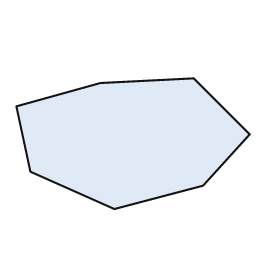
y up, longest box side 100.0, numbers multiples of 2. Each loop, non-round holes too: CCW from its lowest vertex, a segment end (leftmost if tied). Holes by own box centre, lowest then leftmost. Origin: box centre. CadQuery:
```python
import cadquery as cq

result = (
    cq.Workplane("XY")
    .moveTo(-8.0, -28.0)
    .lineTo(30.0, -18.0)
    .lineTo(50.0, 4.0)
    .lineTo(26.0, 28.0)
    .lineTo(-14.0, 26.0)
    .lineTo(-50.0, 16.0)
    .lineTo(-44.0, -12.0)
    .close()
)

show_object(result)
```